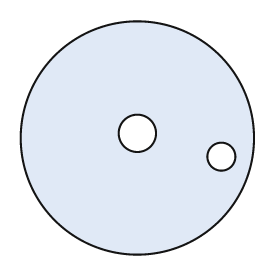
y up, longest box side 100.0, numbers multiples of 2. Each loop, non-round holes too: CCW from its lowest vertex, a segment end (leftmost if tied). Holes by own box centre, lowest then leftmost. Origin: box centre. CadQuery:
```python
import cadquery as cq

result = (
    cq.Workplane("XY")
    .moveTo(0.0, 0.0)
    .circle(50.0)
    .moveTo(36.0, -8.0)
    .circle(6.0)
    .moveTo(0.0, 2.0)
    .circle(8.0)
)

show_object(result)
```